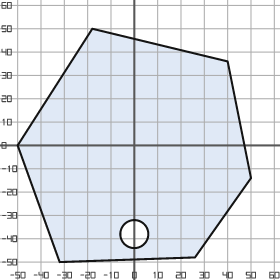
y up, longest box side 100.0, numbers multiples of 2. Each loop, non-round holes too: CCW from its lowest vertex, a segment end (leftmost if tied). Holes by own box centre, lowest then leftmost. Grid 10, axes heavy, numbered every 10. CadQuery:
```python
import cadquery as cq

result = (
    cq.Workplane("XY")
    .moveTo(-32.0, -50.0)
    .lineTo(26.0, -48.0)
    .lineTo(50.0, -14.0)
    .lineTo(40.0, 36.0)
    .lineTo(-18.0, 50.0)
    .lineTo(-50.0, 0.0)
    .close()
    .moveTo(0.0, -38.0)
    .circle(6.0)
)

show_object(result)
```